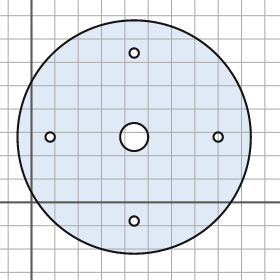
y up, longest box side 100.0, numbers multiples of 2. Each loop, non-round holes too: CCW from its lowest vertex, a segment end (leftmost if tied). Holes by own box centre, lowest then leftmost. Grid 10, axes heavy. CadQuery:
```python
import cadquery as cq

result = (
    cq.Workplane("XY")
    .moveTo(44.0, 28.0)
    .circle(50.0)
    .moveTo(44.0, -8.0)
    .circle(2.0)
    .moveTo(8.0, 28.0)
    .circle(2.0)
    .moveTo(44.0, 28.0)
    .circle(6.0)
    .moveTo(80.0, 28.0)
    .circle(2.0)
    .moveTo(44.0, 64.0)
    .circle(2.0)
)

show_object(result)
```